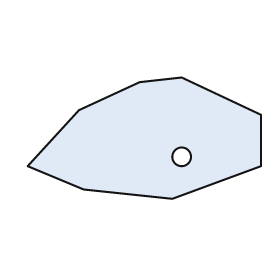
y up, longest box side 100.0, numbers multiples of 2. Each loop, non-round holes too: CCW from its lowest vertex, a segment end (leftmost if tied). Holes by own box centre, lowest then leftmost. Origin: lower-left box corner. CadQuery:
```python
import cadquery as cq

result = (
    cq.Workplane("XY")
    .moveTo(62.0, 0.0)
    .lineTo(100.0, 14.0)
    .lineTo(100.0, 36.0)
    .lineTo(66.0, 52.0)
    .lineTo(48.0, 50.0)
    .lineTo(22.0, 38.0)
    .lineTo(0.0, 14.0)
    .lineTo(24.0, 4.0)
    .close()
    .moveTo(66.0, 18.0)
    .circle(4.0)
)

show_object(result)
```